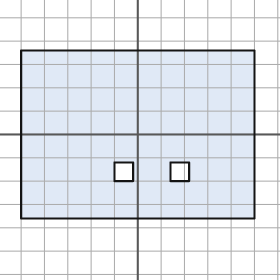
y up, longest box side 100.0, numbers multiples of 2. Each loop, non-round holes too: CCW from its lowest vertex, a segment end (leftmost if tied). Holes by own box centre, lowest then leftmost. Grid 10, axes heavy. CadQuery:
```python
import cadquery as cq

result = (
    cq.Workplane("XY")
    .moveTo(-50.0, -36.0)
    .lineTo(50.0, -36.0)
    .lineTo(50.0, 36.0)
    .lineTo(-50.0, 36.0)
    .close()
    .moveTo(-10.0, -20.0)
    .lineTo(-2.0, -20.0)
    .lineTo(-2.0, -12.0)
    .lineTo(-10.0, -12.0)
    .close()
    .moveTo(14.0, -20.0)
    .lineTo(22.0, -20.0)
    .lineTo(22.0, -12.0)
    .lineTo(14.0, -12.0)
    .close()
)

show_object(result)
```